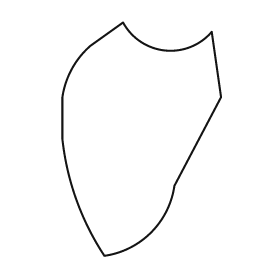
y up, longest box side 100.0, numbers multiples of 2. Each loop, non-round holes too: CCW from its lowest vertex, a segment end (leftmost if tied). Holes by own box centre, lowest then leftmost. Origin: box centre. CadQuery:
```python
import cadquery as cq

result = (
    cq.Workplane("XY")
    .moveTo(-16.0, -50.0)
    .threePointArc((4.0, -40.0), (14.0, -20.0))
    .lineTo(34.0, 18.0)
    .lineTo(30.0, 46.0)
    .threePointArc((10.0, 38.0), (-8.0, 50.0))
    .lineTo(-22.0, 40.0)
    .threePointArc((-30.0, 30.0), (-34.0, 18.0))
    .lineTo(-34.0, 0.0)
    .threePointArc((-28.0, -26.0), (-16.0, -50.0))
    .close()
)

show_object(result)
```